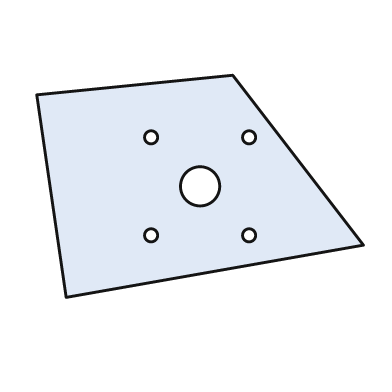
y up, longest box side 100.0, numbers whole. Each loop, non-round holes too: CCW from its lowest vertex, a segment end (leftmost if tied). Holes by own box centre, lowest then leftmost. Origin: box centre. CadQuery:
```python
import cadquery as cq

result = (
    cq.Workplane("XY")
    .moveTo(-41.0, -34.0)
    .lineTo(50.0, -18.0)
    .lineTo(10.0, 34.0)
    .lineTo(-50.0, 28.0)
    .close()
    .moveTo(-15.0, -15.0)
    .circle(2.0)
    .moveTo(15.0, -15.0)
    .circle(2.0)
    .moveTo(0.0, 0.0)
    .circle(6.0)
    .moveTo(-15.0, 15.0)
    .circle(2.0)
    .moveTo(15.0, 15.0)
    .circle(2.0)
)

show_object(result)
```